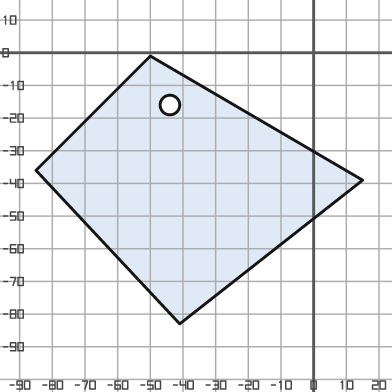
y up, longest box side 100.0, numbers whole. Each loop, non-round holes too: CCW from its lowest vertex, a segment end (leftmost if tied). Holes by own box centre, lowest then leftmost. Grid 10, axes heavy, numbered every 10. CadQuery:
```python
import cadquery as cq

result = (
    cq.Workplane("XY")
    .moveTo(-41.0, -83.0)
    .lineTo(15.0, -39.0)
    .lineTo(-50.0, -1.0)
    .lineTo(-85.0, -36.0)
    .close()
    .moveTo(-44.0, -16.0)
    .circle(3.0)
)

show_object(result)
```